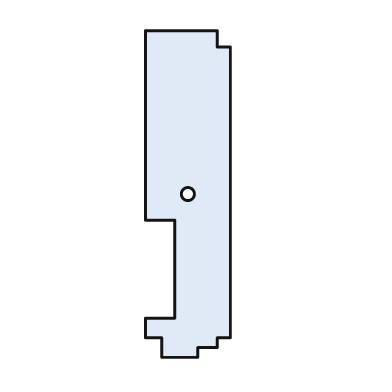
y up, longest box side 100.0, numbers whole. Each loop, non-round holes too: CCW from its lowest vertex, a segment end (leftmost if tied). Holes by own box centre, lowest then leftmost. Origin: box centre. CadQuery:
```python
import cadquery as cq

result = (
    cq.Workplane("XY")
    .moveTo(-8.0, -50.0)
    .lineTo(3.0, -50.0)
    .lineTo(3.0, -47.0)
    .lineTo(9.0, -47.0)
    .lineTo(9.0, -44.0)
    .lineTo(13.0, -44.0)
    .lineTo(13.0, 45.0)
    .lineTo(9.0, 45.0)
    .lineTo(9.0, 50.0)
    .lineTo(-13.0, 50.0)
    .lineTo(-13.0, -8.0)
    .lineTo(-4.0, -8.0)
    .lineTo(-4.0, -38.0)
    .lineTo(-13.0, -38.0)
    .lineTo(-13.0, -44.0)
    .lineTo(-8.0, -44.0)
    .close()
    .moveTo(0.0, 0.0)
    .circle(2.0)
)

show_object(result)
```